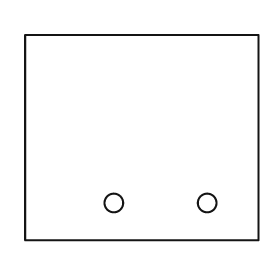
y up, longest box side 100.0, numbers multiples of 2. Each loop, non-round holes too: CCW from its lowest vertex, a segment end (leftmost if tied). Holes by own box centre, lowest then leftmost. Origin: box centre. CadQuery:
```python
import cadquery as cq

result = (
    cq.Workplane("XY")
    .moveTo(-50.0, -44.0)
    .lineTo(50.0, -44.0)
    .lineTo(50.0, 44.0)
    .lineTo(-50.0, 44.0)
    .close()
    .moveTo(-12.0, -28.0)
    .circle(4.0)
    .moveTo(28.0, -28.0)
    .circle(4.0)
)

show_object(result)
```